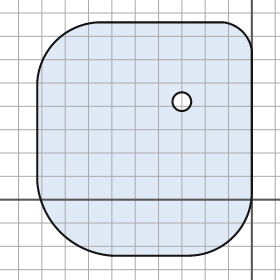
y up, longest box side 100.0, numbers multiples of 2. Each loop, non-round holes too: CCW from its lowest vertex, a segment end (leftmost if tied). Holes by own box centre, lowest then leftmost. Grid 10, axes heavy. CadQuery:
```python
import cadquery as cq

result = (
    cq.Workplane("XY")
    .moveTo(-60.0, -24.0)
    .lineTo(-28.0, -24.0)
    .threePointArc((-8.0, -16.0), (0.0, 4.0))
    .lineTo(0.0, 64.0)
    .threePointArc((-4.0, 72.0), (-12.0, 76.0))
    .lineTo(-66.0, 76.0)
    .threePointArc((-84.0, 68.0), (-92.0, 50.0))
    .lineTo(-92.0, 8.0)
    .threePointArc((-82.0, -14.0), (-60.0, -24.0))
    .close()
    .moveTo(-30.0, 42.0)
    .circle(4.0)
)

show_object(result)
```